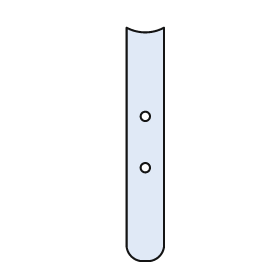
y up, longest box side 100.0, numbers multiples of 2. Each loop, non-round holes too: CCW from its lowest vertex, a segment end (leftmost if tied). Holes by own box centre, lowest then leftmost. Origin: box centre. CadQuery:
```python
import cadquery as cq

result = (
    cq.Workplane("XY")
    .moveTo(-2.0, -50.0)
    .lineTo(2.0, -50.0)
    .threePointArc((6.0, -48.0), (8.0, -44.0))
    .lineTo(8.0, 50.0)
    .threePointArc((0.0, 48.0), (-8.0, 50.0))
    .lineTo(-8.0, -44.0)
    .threePointArc((-6.0, -48.0), (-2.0, -50.0))
    .close()
    .moveTo(0.0, -10.0)
    .circle(2.0)
    .moveTo(0.0, 12.0)
    .circle(2.0)
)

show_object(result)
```